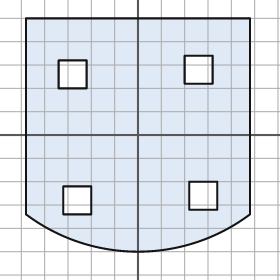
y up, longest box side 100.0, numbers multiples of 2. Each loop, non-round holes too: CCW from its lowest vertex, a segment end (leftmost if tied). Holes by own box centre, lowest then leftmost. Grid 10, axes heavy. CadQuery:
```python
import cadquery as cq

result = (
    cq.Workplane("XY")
    .moveTo(-48.0, -34.0)
    .threePointArc((0.0, -50.0), (48.0, -34.0))
    .lineTo(48.0, 50.0)
    .lineTo(-48.0, 50.0)
    .close()
    .moveTo(-32.0, -34.0)
    .lineTo(-20.0, -34.0)
    .lineTo(-20.0, -22.0)
    .lineTo(-32.0, -22.0)
    .close()
    .moveTo(22.0, -32.0)
    .lineTo(34.0, -32.0)
    .lineTo(34.0, -20.0)
    .lineTo(22.0, -20.0)
    .close()
    .moveTo(-34.0, 20.0)
    .lineTo(-22.0, 20.0)
    .lineTo(-22.0, 32.0)
    .lineTo(-34.0, 32.0)
    .close()
    .moveTo(20.0, 22.0)
    .lineTo(32.0, 22.0)
    .lineTo(32.0, 34.0)
    .lineTo(20.0, 34.0)
    .close()
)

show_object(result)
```